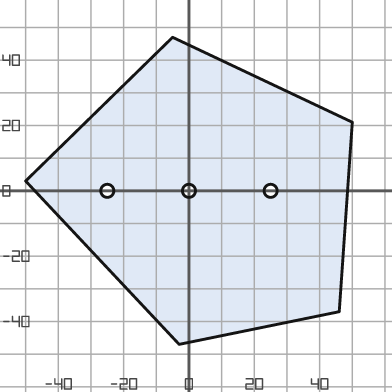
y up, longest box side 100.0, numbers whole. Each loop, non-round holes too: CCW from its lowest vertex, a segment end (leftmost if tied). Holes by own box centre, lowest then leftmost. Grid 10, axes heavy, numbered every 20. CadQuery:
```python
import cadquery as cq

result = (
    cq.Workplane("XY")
    .moveTo(-3.0, -47.0)
    .lineTo(46.0, -37.0)
    .lineTo(50.0, 21.0)
    .lineTo(-5.0, 47.0)
    .lineTo(-50.0, 3.0)
    .close()
    .moveTo(-25.0, 0.0)
    .circle(2.0)
    .moveTo(0.0, 0.0)
    .circle(2.0)
    .moveTo(25.0, 0.0)
    .circle(2.0)
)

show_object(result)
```